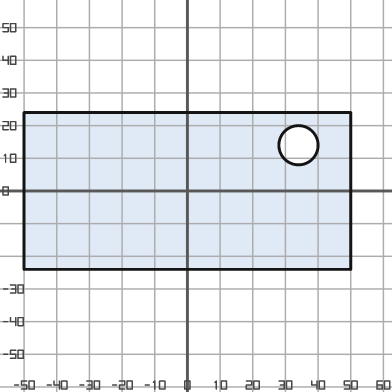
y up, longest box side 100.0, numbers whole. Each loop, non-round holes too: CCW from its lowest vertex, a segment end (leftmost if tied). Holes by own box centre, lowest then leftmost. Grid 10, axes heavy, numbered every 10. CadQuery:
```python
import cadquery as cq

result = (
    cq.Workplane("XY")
    .moveTo(-50.0, -24.0)
    .lineTo(50.0, -24.0)
    .lineTo(50.0, 24.0)
    .lineTo(-50.0, 24.0)
    .close()
    .moveTo(34.0, 14.0)
    .circle(6.0)
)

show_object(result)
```